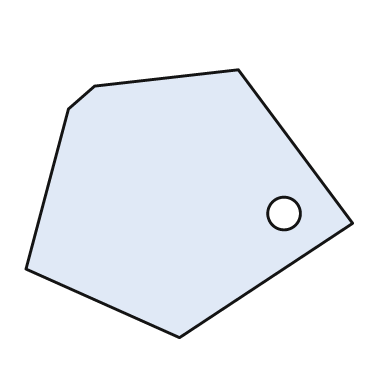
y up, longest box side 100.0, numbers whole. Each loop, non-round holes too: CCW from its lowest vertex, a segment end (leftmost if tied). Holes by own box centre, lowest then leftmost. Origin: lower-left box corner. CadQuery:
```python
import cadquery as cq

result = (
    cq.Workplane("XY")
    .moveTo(47.0, 0.0)
    .lineTo(100.0, 35.0)
    .lineTo(65.0, 82.0)
    .lineTo(21.0, 77.0)
    .lineTo(13.0, 70.0)
    .lineTo(0.0, 21.0)
    .close()
    .moveTo(79.0, 38.0)
    .circle(5.0)
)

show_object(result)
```